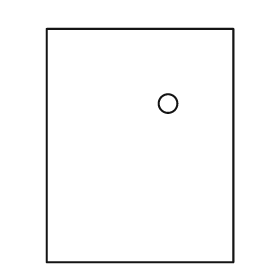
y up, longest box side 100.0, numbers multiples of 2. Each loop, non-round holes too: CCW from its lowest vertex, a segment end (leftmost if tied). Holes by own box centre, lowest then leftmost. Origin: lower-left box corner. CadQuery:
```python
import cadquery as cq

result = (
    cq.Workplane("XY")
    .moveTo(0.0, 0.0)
    .lineTo(80.0, 0.0)
    .lineTo(80.0, 100.0)
    .lineTo(0.0, 100.0)
    .close()
    .moveTo(52.0, 68.0)
    .circle(4.0)
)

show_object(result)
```